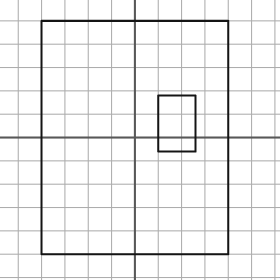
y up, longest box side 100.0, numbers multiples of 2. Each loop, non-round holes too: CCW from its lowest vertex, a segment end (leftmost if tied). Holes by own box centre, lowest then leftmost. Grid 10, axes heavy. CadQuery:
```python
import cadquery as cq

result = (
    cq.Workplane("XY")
    .moveTo(-40.0, -50.0)
    .lineTo(40.0, -50.0)
    .lineTo(40.0, 50.0)
    .lineTo(-40.0, 50.0)
    .close()
    .moveTo(10.0, -6.0)
    .lineTo(26.0, -6.0)
    .lineTo(26.0, 18.0)
    .lineTo(10.0, 18.0)
    .close()
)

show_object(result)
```